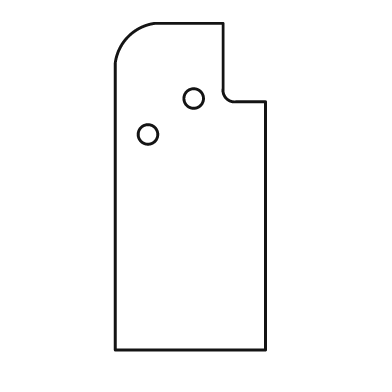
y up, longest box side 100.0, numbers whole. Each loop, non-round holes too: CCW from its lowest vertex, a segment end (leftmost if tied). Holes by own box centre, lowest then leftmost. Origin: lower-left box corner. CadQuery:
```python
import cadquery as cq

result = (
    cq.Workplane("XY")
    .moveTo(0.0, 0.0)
    .lineTo(46.0, 0.0)
    .lineTo(46.0, 76.0)
    .lineTo(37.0, 76.0)
    .threePointArc((34.0, 77.0), (33.0, 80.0))
    .lineTo(33.0, 100.0)
    .lineTo(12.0, 100.0)
    .threePointArc((4.0, 96.0), (0.0, 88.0))
    .close()
    .moveTo(10.0, 66.0)
    .circle(3.0)
    .moveTo(24.0, 77.0)
    .circle(3.0)
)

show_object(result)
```